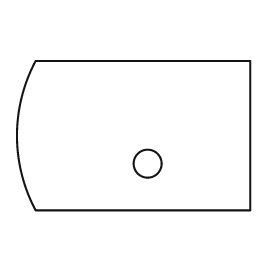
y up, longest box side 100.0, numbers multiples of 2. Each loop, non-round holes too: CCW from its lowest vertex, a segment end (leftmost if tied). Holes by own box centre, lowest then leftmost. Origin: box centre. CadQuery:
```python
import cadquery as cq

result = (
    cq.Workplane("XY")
    .moveTo(-42.0, -32.0)
    .lineTo(50.0, -32.0)
    .lineTo(50.0, 32.0)
    .lineTo(-42.0, 32.0)
    .threePointArc((-50.0, 0.0), (-42.0, -32.0))
    .close()
    .moveTo(6.0, -12.0)
    .circle(6.0)
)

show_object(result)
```